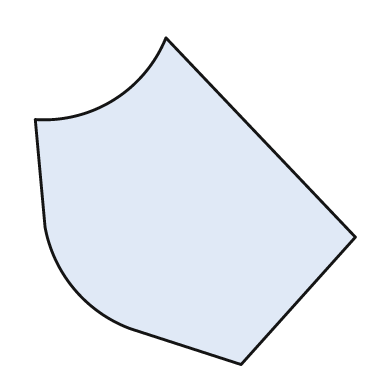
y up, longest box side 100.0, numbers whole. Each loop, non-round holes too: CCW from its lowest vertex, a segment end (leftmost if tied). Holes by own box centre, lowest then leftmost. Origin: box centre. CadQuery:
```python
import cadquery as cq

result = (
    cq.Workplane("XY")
    .moveTo(14.0, -50.0)
    .lineTo(49.0, -11.0)
    .lineTo(-9.0, 50.0)
    .threePointArc((-25.0, 31.0), (-49.0, 25.0))
    .lineTo(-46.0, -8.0)
    .threePointArc((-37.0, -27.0), (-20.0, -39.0))
    .close()
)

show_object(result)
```